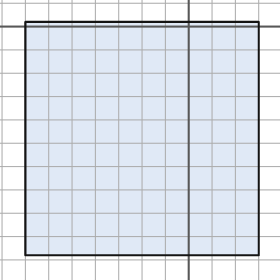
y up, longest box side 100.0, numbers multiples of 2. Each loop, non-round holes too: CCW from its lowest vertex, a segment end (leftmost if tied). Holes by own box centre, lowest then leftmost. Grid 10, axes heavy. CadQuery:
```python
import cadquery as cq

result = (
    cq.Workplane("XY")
    .moveTo(-70.0, -98.0)
    .lineTo(30.0, -98.0)
    .lineTo(30.0, 2.0)
    .lineTo(-70.0, 2.0)
    .close()
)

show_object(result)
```